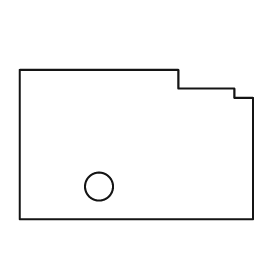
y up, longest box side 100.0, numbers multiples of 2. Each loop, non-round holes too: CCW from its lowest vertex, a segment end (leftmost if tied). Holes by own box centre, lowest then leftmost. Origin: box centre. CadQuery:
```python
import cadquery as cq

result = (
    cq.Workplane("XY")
    .moveTo(-50.0, -32.0)
    .lineTo(50.0, -32.0)
    .lineTo(50.0, 20.0)
    .lineTo(42.0, 20.0)
    .lineTo(42.0, 24.0)
    .lineTo(18.0, 24.0)
    .lineTo(18.0, 32.0)
    .lineTo(-50.0, 32.0)
    .close()
    .moveTo(-16.0, -18.0)
    .circle(6.0)
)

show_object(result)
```